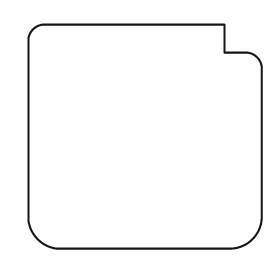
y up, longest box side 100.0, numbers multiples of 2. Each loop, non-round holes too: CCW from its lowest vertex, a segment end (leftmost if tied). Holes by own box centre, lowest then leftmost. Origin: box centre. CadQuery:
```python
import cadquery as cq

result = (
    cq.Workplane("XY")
    .moveTo(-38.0, -48.0)
    .lineTo(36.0, -48.0)
    .threePointArc((46.0, -44.0), (50.0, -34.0))
    .lineTo(50.0, 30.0)
    .threePointArc((48.0, 34.0), (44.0, 36.0))
    .lineTo(34.0, 36.0)
    .lineTo(34.0, 48.0)
    .lineTo(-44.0, 48.0)
    .threePointArc((-48.0, 46.0), (-50.0, 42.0))
    .lineTo(-50.0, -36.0)
    .threePointArc((-46.0, -44.0), (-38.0, -48.0))
    .close()
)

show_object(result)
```